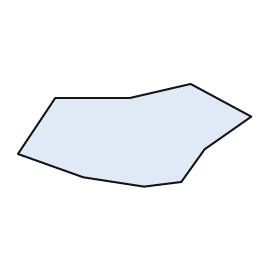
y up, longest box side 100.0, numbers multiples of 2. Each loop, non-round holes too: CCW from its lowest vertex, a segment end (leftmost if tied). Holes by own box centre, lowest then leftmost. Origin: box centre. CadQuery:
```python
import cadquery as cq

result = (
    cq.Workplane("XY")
    .moveTo(4.0, -22.0)
    .lineTo(20.0, -20.0)
    .lineTo(30.0, -6.0)
    .lineTo(50.0, 8.0)
    .lineTo(24.0, 22.0)
    .lineTo(-2.0, 16.0)
    .lineTo(-34.0, 16.0)
    .lineTo(-50.0, -8.0)
    .lineTo(-22.0, -18.0)
    .close()
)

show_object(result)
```